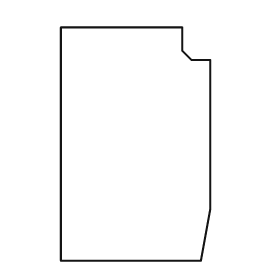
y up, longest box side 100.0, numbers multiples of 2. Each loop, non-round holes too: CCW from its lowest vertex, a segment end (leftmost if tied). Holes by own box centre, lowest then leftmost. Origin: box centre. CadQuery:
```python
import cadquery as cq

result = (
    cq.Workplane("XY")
    .moveTo(-32.0, -50.0)
    .lineTo(28.0, -50.0)
    .lineTo(32.0, -28.0)
    .lineTo(32.0, 36.0)
    .lineTo(24.0, 36.0)
    .lineTo(20.0, 40.0)
    .lineTo(20.0, 50.0)
    .lineTo(-32.0, 50.0)
    .close()
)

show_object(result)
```